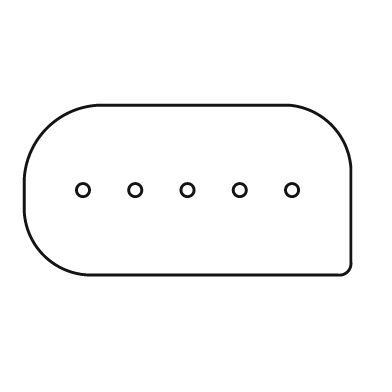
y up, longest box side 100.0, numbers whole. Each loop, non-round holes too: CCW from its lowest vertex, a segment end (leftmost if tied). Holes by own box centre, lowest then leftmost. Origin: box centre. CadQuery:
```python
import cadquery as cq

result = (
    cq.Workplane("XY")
    .moveTo(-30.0, -26.0)
    .lineTo(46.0, -26.0)
    .threePointArc((49.0, -25.0), (50.0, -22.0))
    .lineTo(50.0, 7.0)
    .threePointArc((44.0, 20.0), (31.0, 26.0))
    .lineTo(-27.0, 26.0)
    .threePointArc((-43.0, 19.0), (-50.0, 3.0))
    .lineTo(-50.0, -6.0)
    .threePointArc((-44.0, -20.0), (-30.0, -26.0))
    .close()
    .moveTo(-32.0, 0.0)
    .circle(2.0)
    .moveTo(-16.0, 0.0)
    .circle(2.0)
    .moveTo(0.0, 0.0)
    .circle(2.0)
    .moveTo(16.0, 0.0)
    .circle(2.0)
    .moveTo(32.0, 0.0)
    .circle(2.0)
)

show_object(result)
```